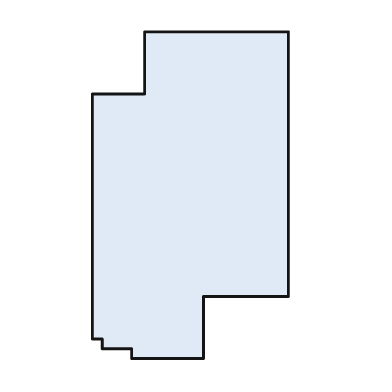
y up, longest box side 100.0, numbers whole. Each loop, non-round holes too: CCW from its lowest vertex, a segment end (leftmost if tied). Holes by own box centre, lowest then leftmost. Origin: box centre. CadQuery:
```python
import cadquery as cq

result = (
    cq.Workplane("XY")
    .moveTo(-18.0, -50.0)
    .lineTo(4.0, -50.0)
    .lineTo(4.0, -31.0)
    .lineTo(30.0, -31.0)
    .lineTo(30.0, 50.0)
    .lineTo(-14.0, 50.0)
    .lineTo(-14.0, 31.0)
    .lineTo(-30.0, 31.0)
    .lineTo(-30.0, -44.0)
    .lineTo(-27.0, -44.0)
    .lineTo(-27.0, -47.0)
    .lineTo(-18.0, -47.0)
    .close()
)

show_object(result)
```